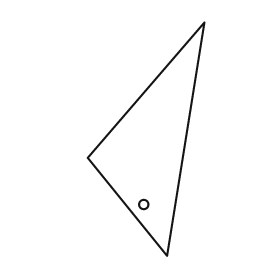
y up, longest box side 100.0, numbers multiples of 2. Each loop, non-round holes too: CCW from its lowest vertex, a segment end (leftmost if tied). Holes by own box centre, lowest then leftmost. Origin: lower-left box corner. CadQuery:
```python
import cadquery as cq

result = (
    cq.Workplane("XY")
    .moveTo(34.0, 0.0)
    .lineTo(50.0, 100.0)
    .lineTo(0.0, 42.0)
    .close()
    .moveTo(24.0, 22.0)
    .circle(2.0)
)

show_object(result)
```